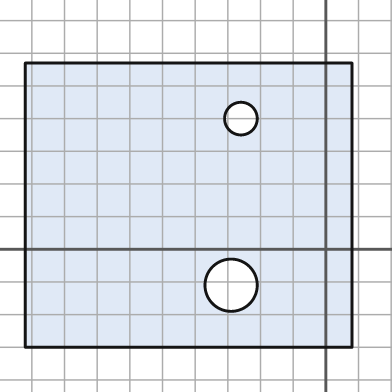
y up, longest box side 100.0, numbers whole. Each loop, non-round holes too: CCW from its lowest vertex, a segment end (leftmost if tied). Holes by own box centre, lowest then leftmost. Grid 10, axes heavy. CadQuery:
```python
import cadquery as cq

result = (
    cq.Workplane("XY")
    .moveTo(-92.0, -30.0)
    .lineTo(8.0, -30.0)
    .lineTo(8.0, 57.0)
    .lineTo(-92.0, 57.0)
    .close()
    .moveTo(-29.0, -11.0)
    .circle(8.0)
    .moveTo(-26.0, 40.0)
    .circle(5.0)
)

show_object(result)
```